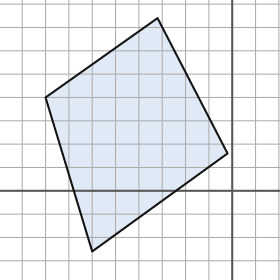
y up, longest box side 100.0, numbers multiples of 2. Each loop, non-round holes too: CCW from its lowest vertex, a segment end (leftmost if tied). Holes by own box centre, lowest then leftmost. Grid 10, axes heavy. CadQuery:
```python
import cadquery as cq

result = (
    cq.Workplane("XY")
    .moveTo(-60.0, -26.0)
    .lineTo(-2.0, 16.0)
    .lineTo(-32.0, 74.0)
    .lineTo(-80.0, 40.0)
    .close()
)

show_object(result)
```